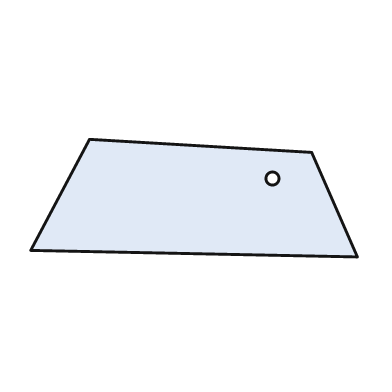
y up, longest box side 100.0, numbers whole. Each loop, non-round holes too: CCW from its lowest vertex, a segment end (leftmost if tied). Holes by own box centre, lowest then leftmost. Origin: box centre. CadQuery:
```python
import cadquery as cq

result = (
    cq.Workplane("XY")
    .moveTo(50.0, -18.0)
    .lineTo(36.0, 14.0)
    .lineTo(-32.0, 18.0)
    .lineTo(-50.0, -16.0)
    .close()
    .moveTo(24.0, 6.0)
    .circle(2.0)
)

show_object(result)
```